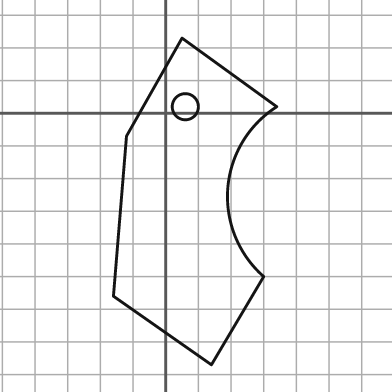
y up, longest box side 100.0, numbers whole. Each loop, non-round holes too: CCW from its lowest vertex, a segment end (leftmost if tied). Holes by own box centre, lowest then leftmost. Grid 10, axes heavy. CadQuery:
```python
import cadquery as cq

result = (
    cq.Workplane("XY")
    .moveTo(14.0, -77.0)
    .lineTo(30.0, -50.0)
    .threePointArc((19.0, -23.0), (34.0, 2.0))
    .lineTo(5.0, 23.0)
    .lineTo(-12.0, -7.0)
    .lineTo(-16.0, -56.0)
    .close()
    .moveTo(6.0, 2.0)
    .circle(4.0)
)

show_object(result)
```